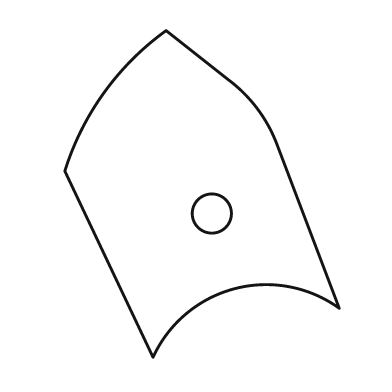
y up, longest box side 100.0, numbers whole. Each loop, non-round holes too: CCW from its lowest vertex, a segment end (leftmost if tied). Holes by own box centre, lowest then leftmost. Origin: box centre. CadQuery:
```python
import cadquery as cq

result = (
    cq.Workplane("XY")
    .moveTo(-15.0, -50.0)
    .threePointArc((10.0, -29.0), (42.0, -35.0))
    .lineTo(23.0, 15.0)
    .threePointArc((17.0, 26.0), (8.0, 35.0))
    .lineTo(-11.0, 50.0)
    .threePointArc((-30.0, 31.0), (-42.0, 7.0))
    .close()
    .moveTo(3.0, -6.0)
    .circle(6.0)
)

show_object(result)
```